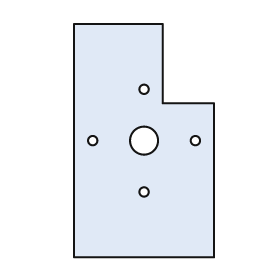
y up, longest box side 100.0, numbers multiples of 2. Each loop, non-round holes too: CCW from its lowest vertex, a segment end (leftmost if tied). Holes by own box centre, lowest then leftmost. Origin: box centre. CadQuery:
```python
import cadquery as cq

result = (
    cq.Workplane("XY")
    .moveTo(-30.0, -50.0)
    .lineTo(30.0, -50.0)
    .lineTo(30.0, 16.0)
    .lineTo(8.0, 16.0)
    .lineTo(8.0, 50.0)
    .lineTo(-30.0, 50.0)
    .close()
    .moveTo(0.0, -22.0)
    .circle(2.0)
    .moveTo(-22.0, 0.0)
    .circle(2.0)
    .moveTo(0.0, 0.0)
    .circle(6.0)
    .moveTo(22.0, 0.0)
    .circle(2.0)
    .moveTo(0.0, 22.0)
    .circle(2.0)
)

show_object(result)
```